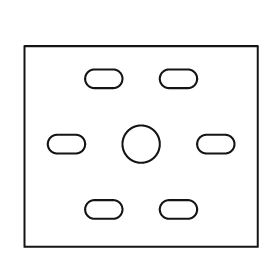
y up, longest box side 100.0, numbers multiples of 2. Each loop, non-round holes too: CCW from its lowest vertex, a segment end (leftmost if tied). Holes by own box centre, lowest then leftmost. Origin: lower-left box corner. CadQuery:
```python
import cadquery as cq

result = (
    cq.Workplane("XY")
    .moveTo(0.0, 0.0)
    .lineTo(100.0, 0.0)
    .lineTo(100.0, 86.0)
    .lineTo(0.0, 86.0)
    .close()
    .moveTo(30.0, 12.0)
    .lineTo(38.0, 12.0)
    .threePointArc((42.0, 16.0), (38.0, 20.0))
    .lineTo(30.0, 20.0)
    .threePointArc((26.0, 16.0), (30.0, 12.0))
    .close()
    .moveTo(62.0, 12.0)
    .lineTo(70.0, 12.0)
    .threePointArc((74.0, 16.0), (70.0, 20.0))
    .lineTo(62.0, 20.0)
    .threePointArc((58.0, 16.0), (62.0, 12.0))
    .close()
    .moveTo(14.0, 40.0)
    .lineTo(22.0, 40.0)
    .threePointArc((26.0, 44.0), (22.0, 48.0))
    .lineTo(14.0, 48.0)
    .threePointArc((10.0, 44.0), (14.0, 40.0))
    .close()
    .moveTo(50.0, 44.0)
    .circle(8.0)
    .moveTo(78.0, 40.0)
    .lineTo(86.0, 40.0)
    .threePointArc((90.0, 44.0), (86.0, 48.0))
    .lineTo(78.0, 48.0)
    .threePointArc((74.0, 44.0), (78.0, 40.0))
    .close()
    .moveTo(30.0, 68.0)
    .lineTo(38.0, 68.0)
    .threePointArc((42.0, 72.0), (38.0, 76.0))
    .lineTo(30.0, 76.0)
    .threePointArc((26.0, 72.0), (30.0, 68.0))
    .close()
    .moveTo(62.0, 68.0)
    .lineTo(70.0, 68.0)
    .threePointArc((74.0, 72.0), (70.0, 76.0))
    .lineTo(62.0, 76.0)
    .threePointArc((58.0, 72.0), (62.0, 68.0))
    .close()
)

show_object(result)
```